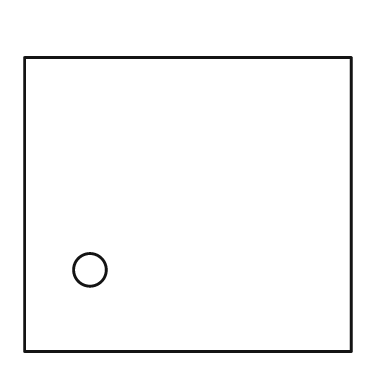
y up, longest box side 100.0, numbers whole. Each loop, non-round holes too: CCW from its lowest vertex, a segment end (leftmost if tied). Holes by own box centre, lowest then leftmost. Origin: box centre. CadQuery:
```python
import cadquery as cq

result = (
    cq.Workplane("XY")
    .moveTo(-50.0, -45.0)
    .lineTo(50.0, -45.0)
    .lineTo(50.0, 45.0)
    .lineTo(-50.0, 45.0)
    .close()
    .moveTo(-30.0, -20.0)
    .circle(5.0)
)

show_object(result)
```